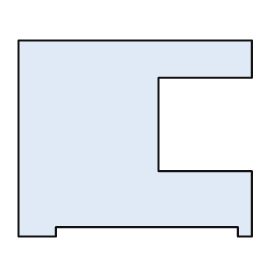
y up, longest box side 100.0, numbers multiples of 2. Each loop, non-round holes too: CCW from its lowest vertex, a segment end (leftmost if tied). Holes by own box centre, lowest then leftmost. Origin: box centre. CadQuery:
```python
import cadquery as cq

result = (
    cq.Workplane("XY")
    .moveTo(-50.0, -42.0)
    .lineTo(-34.0, -42.0)
    .lineTo(-34.0, -38.0)
    .lineTo(44.0, -38.0)
    .lineTo(44.0, -42.0)
    .lineTo(50.0, -42.0)
    .lineTo(50.0, -14.0)
    .lineTo(10.0, -14.0)
    .lineTo(10.0, 26.0)
    .lineTo(50.0, 26.0)
    .lineTo(50.0, 42.0)
    .lineTo(-50.0, 42.0)
    .close()
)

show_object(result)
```